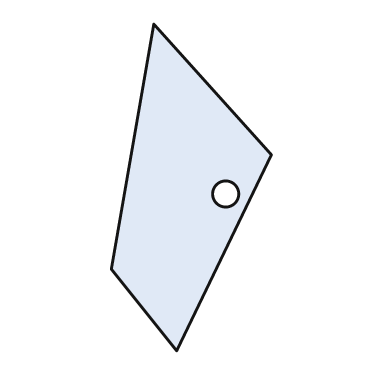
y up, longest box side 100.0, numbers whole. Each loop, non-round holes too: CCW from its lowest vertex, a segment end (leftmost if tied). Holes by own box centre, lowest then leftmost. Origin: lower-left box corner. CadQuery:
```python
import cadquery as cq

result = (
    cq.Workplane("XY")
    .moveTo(20.0, 0.0)
    .lineTo(49.0, 60.0)
    .lineTo(13.0, 100.0)
    .lineTo(0.0, 25.0)
    .close()
    .moveTo(35.0, 48.0)
    .circle(4.0)
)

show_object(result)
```